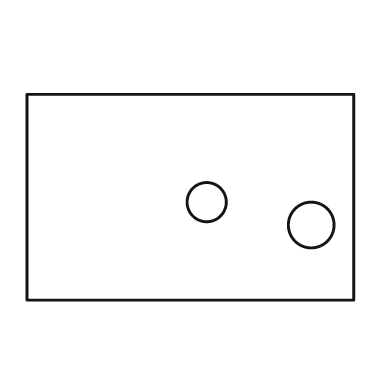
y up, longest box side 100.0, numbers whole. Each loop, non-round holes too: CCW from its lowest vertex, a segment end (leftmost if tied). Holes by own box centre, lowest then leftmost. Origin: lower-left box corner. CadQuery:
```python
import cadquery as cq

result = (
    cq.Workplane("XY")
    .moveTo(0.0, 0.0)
    .lineTo(100.0, 0.0)
    .lineTo(100.0, 63.0)
    .lineTo(0.0, 63.0)
    .close()
    .moveTo(87.0, 23.0)
    .circle(7.0)
    .moveTo(55.0, 30.0)
    .circle(6.0)
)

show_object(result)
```